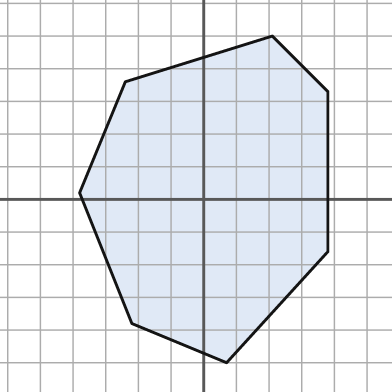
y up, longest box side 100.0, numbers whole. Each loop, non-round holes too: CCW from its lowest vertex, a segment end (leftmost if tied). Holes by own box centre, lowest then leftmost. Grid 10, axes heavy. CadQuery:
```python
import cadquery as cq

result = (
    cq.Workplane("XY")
    .moveTo(7.0, -50.0)
    .lineTo(38.0, -16.0)
    .lineTo(38.0, 33.0)
    .lineTo(21.0, 50.0)
    .lineTo(-24.0, 36.0)
    .lineTo(-38.0, 2.0)
    .lineTo(-22.0, -38.0)
    .close()
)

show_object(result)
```